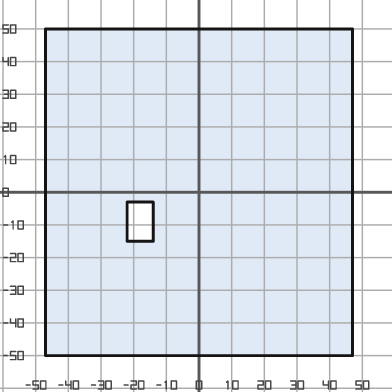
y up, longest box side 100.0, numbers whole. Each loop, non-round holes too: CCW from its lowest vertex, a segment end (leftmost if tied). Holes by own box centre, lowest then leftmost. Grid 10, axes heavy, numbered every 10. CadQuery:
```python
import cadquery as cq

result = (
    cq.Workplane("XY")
    .moveTo(-47.0, -50.0)
    .lineTo(47.0, -50.0)
    .lineTo(47.0, 50.0)
    .lineTo(-47.0, 50.0)
    .close()
    .moveTo(-22.0, -15.0)
    .lineTo(-14.0, -15.0)
    .lineTo(-14.0, -3.0)
    .lineTo(-22.0, -3.0)
    .close()
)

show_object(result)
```